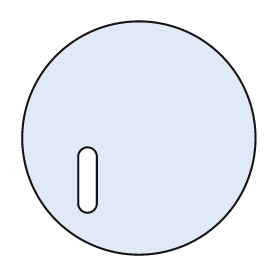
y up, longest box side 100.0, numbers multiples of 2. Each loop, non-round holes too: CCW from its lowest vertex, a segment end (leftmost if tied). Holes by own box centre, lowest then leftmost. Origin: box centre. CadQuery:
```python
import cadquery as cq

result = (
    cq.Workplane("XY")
    .moveTo(0.0, 0.0)
    .circle(50.0)
    .moveTo(-26.0, -28.0)
    .threePointArc((-22.0, -32.0), (-18.0, -28.0))
    .lineTo(-18.0, -8.0)
    .threePointArc((-22.0, -4.0), (-26.0, -8.0))
    .close()
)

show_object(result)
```